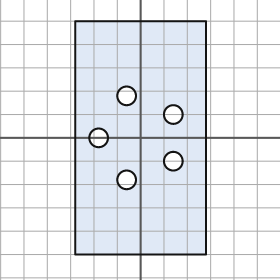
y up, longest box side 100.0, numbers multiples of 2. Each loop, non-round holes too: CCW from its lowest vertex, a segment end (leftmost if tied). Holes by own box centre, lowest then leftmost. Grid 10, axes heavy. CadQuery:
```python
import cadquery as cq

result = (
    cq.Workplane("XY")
    .moveTo(-28.0, -50.0)
    .lineTo(28.0, -50.0)
    .lineTo(28.0, 50.0)
    .lineTo(-28.0, 50.0)
    .close()
    .moveTo(-6.0, -18.0)
    .circle(4.0)
    .moveTo(14.0, -10.0)
    .circle(4.0)
    .moveTo(-18.0, 0.0)
    .circle(4.0)
    .moveTo(14.0, 10.0)
    .circle(4.0)
    .moveTo(-6.0, 18.0)
    .circle(4.0)
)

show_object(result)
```